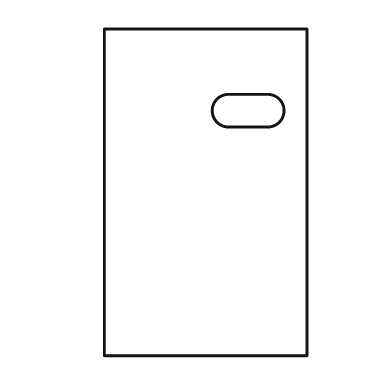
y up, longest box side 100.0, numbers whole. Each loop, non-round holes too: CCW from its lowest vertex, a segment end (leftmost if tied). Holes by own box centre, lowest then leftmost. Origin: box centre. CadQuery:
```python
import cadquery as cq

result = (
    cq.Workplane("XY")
    .moveTo(-31.0, -50.0)
    .lineTo(31.0, -50.0)
    .lineTo(31.0, 50.0)
    .lineTo(-31.0, 50.0)
    .close()
    .moveTo(7.0, 20.0)
    .lineTo(19.0, 20.0)
    .threePointArc((24.0, 25.0), (19.0, 30.0))
    .lineTo(7.0, 30.0)
    .threePointArc((2.0, 25.0), (7.0, 20.0))
    .close()
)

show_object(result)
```